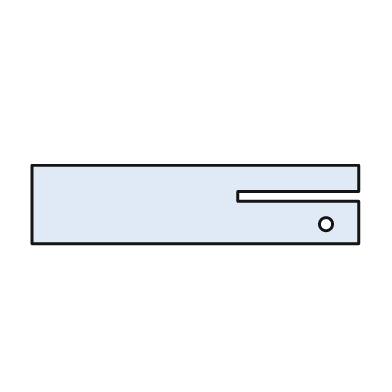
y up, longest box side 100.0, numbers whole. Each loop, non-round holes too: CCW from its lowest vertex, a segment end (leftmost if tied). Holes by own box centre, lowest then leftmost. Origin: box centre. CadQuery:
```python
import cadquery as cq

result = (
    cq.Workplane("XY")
    .moveTo(-50.0, -12.0)
    .lineTo(50.0, -12.0)
    .lineTo(50.0, 1.0)
    .lineTo(13.0, 1.0)
    .lineTo(13.0, 4.0)
    .lineTo(50.0, 4.0)
    .lineTo(50.0, 12.0)
    .lineTo(-50.0, 12.0)
    .close()
    .moveTo(40.0, -6.0)
    .circle(2.0)
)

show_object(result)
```